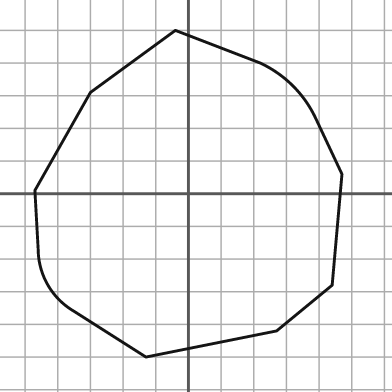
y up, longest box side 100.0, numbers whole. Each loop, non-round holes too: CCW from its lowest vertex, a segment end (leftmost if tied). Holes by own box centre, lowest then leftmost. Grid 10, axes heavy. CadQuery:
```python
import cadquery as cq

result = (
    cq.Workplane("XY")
    .moveTo(-13.0, -50.0)
    .lineTo(27.0, -42.0)
    .lineTo(44.0, -28.0)
    .lineTo(47.0, 6.0)
    .lineTo(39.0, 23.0)
    .threePointArc((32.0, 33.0), (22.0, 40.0))
    .lineTo(-4.0, 50.0)
    .lineTo(-30.0, 31.0)
    .lineTo(-47.0, 1.0)
    .lineTo(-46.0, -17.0)
    .threePointArc((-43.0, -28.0), (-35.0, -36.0))
    .close()
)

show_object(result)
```